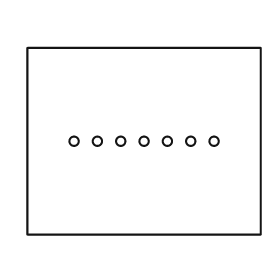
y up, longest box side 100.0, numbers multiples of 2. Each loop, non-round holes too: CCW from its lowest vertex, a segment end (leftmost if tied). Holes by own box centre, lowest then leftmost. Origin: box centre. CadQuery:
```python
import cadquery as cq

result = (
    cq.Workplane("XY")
    .moveTo(-50.0, -40.0)
    .lineTo(50.0, -40.0)
    .lineTo(50.0, 40.0)
    .lineTo(-50.0, 40.0)
    .close()
    .moveTo(-30.0, 0.0)
    .circle(2.0)
    .moveTo(-20.0, 0.0)
    .circle(2.0)
    .moveTo(-10.0, 0.0)
    .circle(2.0)
    .moveTo(0.0, 0.0)
    .circle(2.0)
    .moveTo(10.0, 0.0)
    .circle(2.0)
    .moveTo(20.0, 0.0)
    .circle(2.0)
    .moveTo(30.0, 0.0)
    .circle(2.0)
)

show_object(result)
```